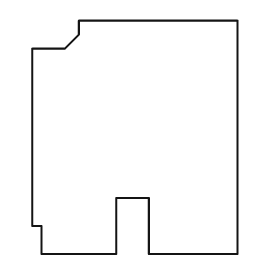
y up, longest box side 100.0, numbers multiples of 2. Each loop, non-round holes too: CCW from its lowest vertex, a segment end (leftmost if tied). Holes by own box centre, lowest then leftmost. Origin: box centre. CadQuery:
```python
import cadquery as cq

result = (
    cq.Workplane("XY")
    .moveTo(-40.0, -50.0)
    .lineTo(-8.0, -50.0)
    .lineTo(-8.0, -26.0)
    .lineTo(6.0, -26.0)
    .lineTo(6.0, -50.0)
    .lineTo(44.0, -50.0)
    .lineTo(44.0, 50.0)
    .lineTo(-24.0, 50.0)
    .lineTo(-24.0, 44.0)
    .lineTo(-30.0, 38.0)
    .lineTo(-44.0, 38.0)
    .lineTo(-44.0, -38.0)
    .lineTo(-40.0, -38.0)
    .close()
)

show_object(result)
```